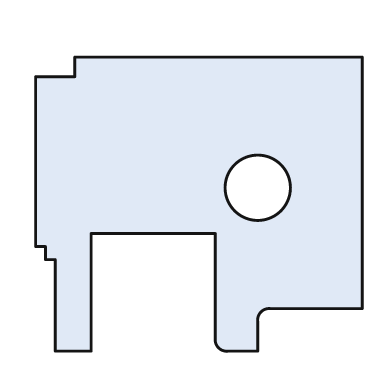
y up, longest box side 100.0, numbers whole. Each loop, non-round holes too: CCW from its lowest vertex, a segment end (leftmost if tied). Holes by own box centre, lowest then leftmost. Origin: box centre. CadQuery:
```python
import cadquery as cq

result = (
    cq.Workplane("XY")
    .moveTo(-44.0, -45.0)
    .lineTo(-33.0, -45.0)
    .lineTo(-33.0, -9.0)
    .lineTo(5.0, -9.0)
    .lineTo(5.0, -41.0)
    .threePointArc((6.0, -44.0), (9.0, -45.0))
    .lineTo(18.0, -45.0)
    .lineTo(18.0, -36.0)
    .threePointArc((19.0, -33.0), (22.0, -32.0))
    .lineTo(50.0, -32.0)
    .lineTo(50.0, 45.0)
    .lineTo(-38.0, 45.0)
    .lineTo(-38.0, 39.0)
    .lineTo(-50.0, 39.0)
    .lineTo(-50.0, -13.0)
    .lineTo(-47.0, -13.0)
    .lineTo(-47.0, -17.0)
    .lineTo(-44.0, -17.0)
    .close()
    .moveTo(18.0, 5.0)
    .circle(10.0)
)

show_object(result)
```